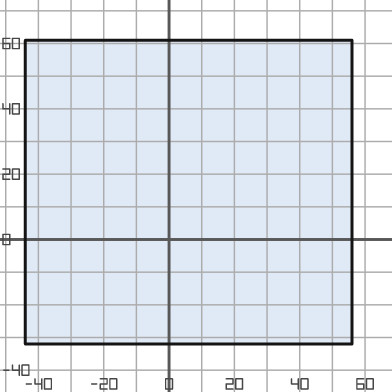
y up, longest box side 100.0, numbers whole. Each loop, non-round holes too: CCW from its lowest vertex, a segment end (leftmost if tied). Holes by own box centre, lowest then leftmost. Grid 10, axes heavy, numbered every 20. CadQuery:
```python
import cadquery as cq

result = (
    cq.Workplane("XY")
    .moveTo(-44.0, -32.0)
    .lineTo(56.0, -32.0)
    .lineTo(56.0, 61.0)
    .lineTo(-44.0, 61.0)
    .close()
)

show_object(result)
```